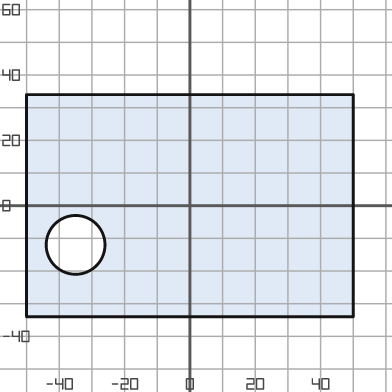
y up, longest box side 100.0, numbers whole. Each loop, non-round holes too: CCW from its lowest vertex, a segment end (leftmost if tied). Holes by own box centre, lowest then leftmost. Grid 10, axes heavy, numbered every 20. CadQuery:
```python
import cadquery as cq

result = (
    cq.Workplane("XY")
    .moveTo(-50.0, -34.0)
    .lineTo(50.0, -34.0)
    .lineTo(50.0, 34.0)
    .lineTo(-50.0, 34.0)
    .close()
    .moveTo(-35.0, -12.0)
    .circle(9.0)
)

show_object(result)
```